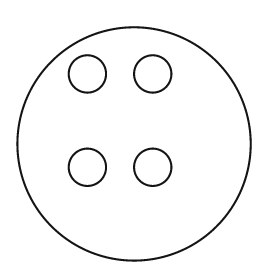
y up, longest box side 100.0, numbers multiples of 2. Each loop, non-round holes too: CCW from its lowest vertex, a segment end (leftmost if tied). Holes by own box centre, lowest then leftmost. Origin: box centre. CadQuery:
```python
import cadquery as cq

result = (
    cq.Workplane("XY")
    .moveTo(0.0, 0.0)
    .circle(50.0)
    .moveTo(-20.0, -10.0)
    .circle(8.0)
    .moveTo(8.0, -10.0)
    .circle(8.0)
    .moveTo(-20.0, 30.0)
    .circle(8.0)
    .moveTo(8.0, 30.0)
    .circle(8.0)
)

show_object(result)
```